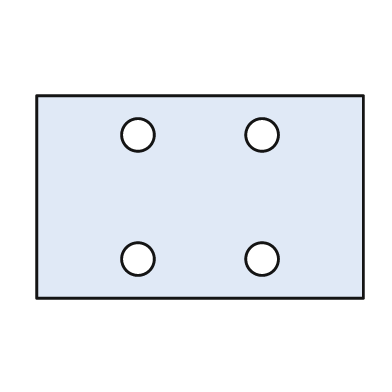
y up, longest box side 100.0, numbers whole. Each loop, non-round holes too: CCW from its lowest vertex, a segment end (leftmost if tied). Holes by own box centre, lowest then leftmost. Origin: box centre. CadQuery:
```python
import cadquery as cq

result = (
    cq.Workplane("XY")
    .moveTo(-50.0, -31.0)
    .lineTo(50.0, -31.0)
    .lineTo(50.0, 31.0)
    .lineTo(-50.0, 31.0)
    .close()
    .moveTo(-19.0, -19.0)
    .circle(5.0)
    .moveTo(19.0, -19.0)
    .circle(5.0)
    .moveTo(-19.0, 19.0)
    .circle(5.0)
    .moveTo(19.0, 19.0)
    .circle(5.0)
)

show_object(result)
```